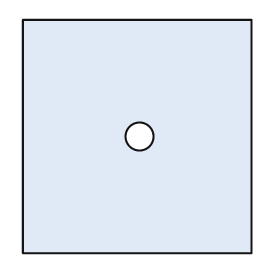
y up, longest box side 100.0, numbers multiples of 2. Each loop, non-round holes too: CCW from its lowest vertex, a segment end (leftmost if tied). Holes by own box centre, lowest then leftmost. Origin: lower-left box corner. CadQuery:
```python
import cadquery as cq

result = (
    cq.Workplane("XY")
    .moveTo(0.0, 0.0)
    .lineTo(98.0, 0.0)
    .lineTo(98.0, 100.0)
    .lineTo(0.0, 100.0)
    .close()
    .moveTo(50.0, 50.0)
    .circle(6.0)
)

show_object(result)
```